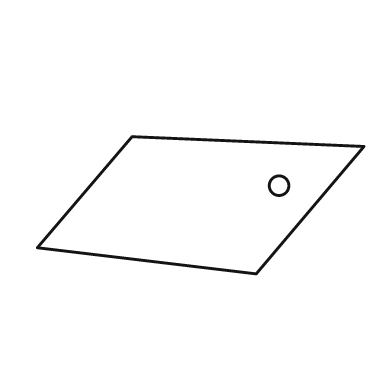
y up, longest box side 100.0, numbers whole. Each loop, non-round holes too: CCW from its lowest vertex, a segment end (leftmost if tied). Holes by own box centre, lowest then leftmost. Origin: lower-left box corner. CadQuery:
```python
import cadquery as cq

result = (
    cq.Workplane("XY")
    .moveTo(67.0, 0.0)
    .lineTo(100.0, 39.0)
    .lineTo(29.0, 42.0)
    .lineTo(0.0, 8.0)
    .close()
    .moveTo(74.0, 27.0)
    .circle(3.0)
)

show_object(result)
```